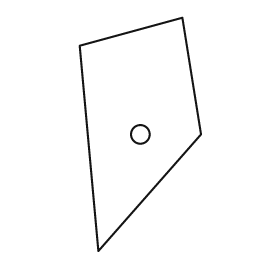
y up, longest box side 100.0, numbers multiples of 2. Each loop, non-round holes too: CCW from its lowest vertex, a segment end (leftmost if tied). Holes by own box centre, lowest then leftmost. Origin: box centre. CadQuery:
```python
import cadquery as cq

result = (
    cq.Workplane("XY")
    .moveTo(-18.0, -50.0)
    .lineTo(26.0, 0.0)
    .lineTo(18.0, 50.0)
    .lineTo(-26.0, 38.0)
    .close()
    .moveTo(0.0, 0.0)
    .circle(4.0)
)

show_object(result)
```